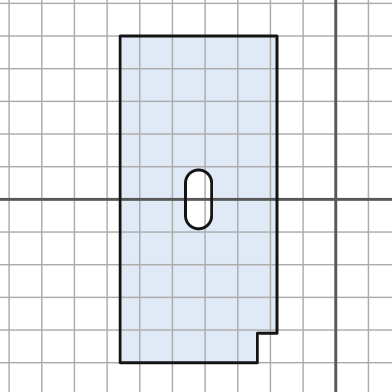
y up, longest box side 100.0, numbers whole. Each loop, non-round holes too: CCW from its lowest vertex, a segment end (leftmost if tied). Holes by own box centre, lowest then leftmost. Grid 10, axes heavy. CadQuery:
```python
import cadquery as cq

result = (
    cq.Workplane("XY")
    .moveTo(-66.0, -50.0)
    .lineTo(-24.0, -50.0)
    .lineTo(-24.0, -41.0)
    .lineTo(-18.0, -41.0)
    .lineTo(-18.0, 50.0)
    .lineTo(-66.0, 50.0)
    .close()
    .moveTo(-46.0, -5.0)
    .threePointArc((-42.0, -9.0), (-38.0, -5.0))
    .lineTo(-38.0, 5.0)
    .threePointArc((-42.0, 9.0), (-46.0, 5.0))
    .close()
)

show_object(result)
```